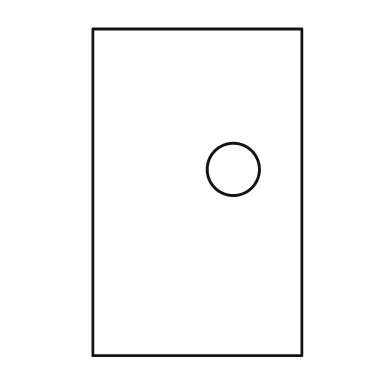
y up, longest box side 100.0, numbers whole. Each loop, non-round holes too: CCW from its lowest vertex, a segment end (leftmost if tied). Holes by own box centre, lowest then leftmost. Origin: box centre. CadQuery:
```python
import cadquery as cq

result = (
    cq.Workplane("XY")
    .moveTo(-32.0, -50.0)
    .lineTo(32.0, -50.0)
    .lineTo(32.0, 50.0)
    .lineTo(-32.0, 50.0)
    .close()
    .moveTo(11.0, 7.0)
    .circle(8.0)
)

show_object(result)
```